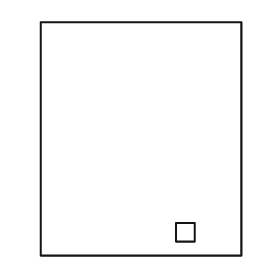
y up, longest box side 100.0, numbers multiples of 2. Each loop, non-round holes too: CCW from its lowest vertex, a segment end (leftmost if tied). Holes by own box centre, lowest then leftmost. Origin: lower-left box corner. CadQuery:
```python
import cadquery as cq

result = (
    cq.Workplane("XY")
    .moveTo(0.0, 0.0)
    .lineTo(86.0, 0.0)
    .lineTo(86.0, 100.0)
    .lineTo(0.0, 100.0)
    .close()
    .moveTo(58.0, 6.0)
    .lineTo(66.0, 6.0)
    .lineTo(66.0, 14.0)
    .lineTo(58.0, 14.0)
    .close()
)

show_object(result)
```